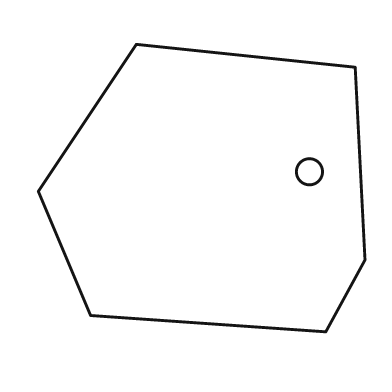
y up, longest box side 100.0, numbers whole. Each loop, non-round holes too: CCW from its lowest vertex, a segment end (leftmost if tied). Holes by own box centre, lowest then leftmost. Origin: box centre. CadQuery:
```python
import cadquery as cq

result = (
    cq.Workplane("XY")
    .moveTo(38.0, -44.0)
    .lineTo(50.0, -22.0)
    .lineTo(47.0, 37.0)
    .lineTo(-20.0, 44.0)
    .lineTo(-50.0, -1.0)
    .lineTo(-34.0, -39.0)
    .close()
    .moveTo(33.0, 5.0)
    .circle(4.0)
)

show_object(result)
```